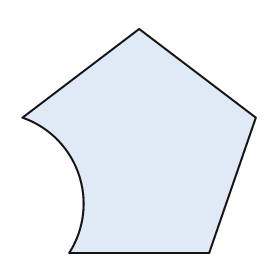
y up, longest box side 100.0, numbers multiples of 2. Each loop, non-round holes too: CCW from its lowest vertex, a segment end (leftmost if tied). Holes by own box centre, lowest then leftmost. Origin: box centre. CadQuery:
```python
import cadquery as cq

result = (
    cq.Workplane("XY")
    .moveTo(-30.0, -48.0)
    .lineTo(30.0, -48.0)
    .lineTo(50.0, 10.0)
    .lineTo(0.0, 48.0)
    .lineTo(-50.0, 10.0)
    .threePointArc((-26.0, -14.0), (-30.0, -48.0))
    .close()
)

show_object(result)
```